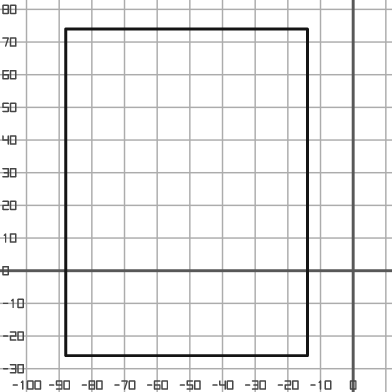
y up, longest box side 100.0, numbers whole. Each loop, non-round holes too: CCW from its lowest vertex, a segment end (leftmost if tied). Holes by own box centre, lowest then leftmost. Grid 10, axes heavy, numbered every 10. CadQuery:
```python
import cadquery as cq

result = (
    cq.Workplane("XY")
    .moveTo(-88.0, -26.0)
    .lineTo(-14.0, -26.0)
    .lineTo(-14.0, 74.0)
    .lineTo(-88.0, 74.0)
    .close()
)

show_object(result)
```